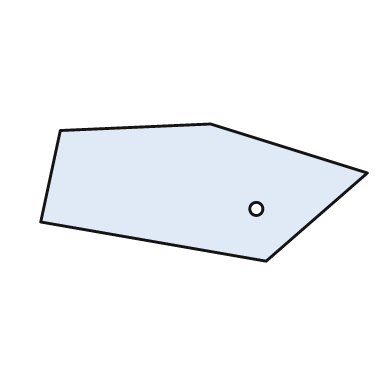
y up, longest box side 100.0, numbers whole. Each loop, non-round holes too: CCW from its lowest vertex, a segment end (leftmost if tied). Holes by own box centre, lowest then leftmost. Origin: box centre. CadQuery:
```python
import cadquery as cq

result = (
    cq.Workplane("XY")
    .moveTo(19.0, -21.0)
    .lineTo(50.0, 6.0)
    .lineTo(2.0, 21.0)
    .lineTo(-44.0, 19.0)
    .lineTo(-50.0, -9.0)
    .close()
    .moveTo(16.0, -5.0)
    .circle(2.0)
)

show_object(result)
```